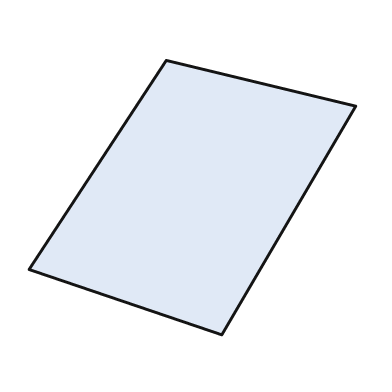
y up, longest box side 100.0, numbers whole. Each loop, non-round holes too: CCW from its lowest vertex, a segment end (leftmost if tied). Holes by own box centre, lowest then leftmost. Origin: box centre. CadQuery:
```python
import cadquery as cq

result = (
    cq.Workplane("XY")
    .moveTo(9.0, -42.0)
    .lineTo(50.0, 28.0)
    .lineTo(-8.0, 42.0)
    .lineTo(-50.0, -22.0)
    .close()
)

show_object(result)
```